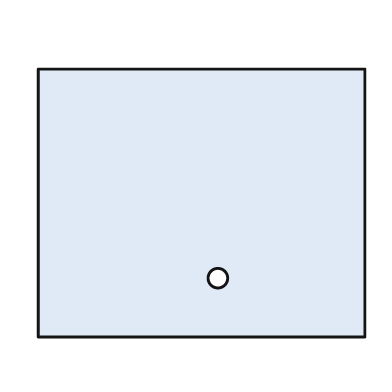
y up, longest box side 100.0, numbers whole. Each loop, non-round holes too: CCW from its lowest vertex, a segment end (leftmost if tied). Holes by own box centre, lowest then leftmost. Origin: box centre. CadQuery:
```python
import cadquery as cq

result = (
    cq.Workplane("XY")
    .moveTo(-50.0, -41.0)
    .lineTo(50.0, -41.0)
    .lineTo(50.0, 41.0)
    .lineTo(-50.0, 41.0)
    .close()
    .moveTo(5.0, -23.0)
    .circle(3.0)
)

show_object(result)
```